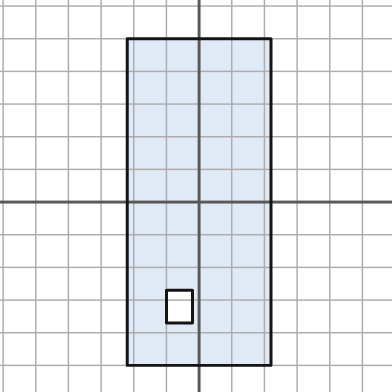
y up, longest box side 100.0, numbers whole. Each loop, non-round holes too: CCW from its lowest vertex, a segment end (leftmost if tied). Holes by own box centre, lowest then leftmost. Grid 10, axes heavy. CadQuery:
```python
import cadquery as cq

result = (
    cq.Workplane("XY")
    .moveTo(-22.0, -50.0)
    .lineTo(22.0, -50.0)
    .lineTo(22.0, 50.0)
    .lineTo(-22.0, 50.0)
    .close()
    .moveTo(-10.0, -37.0)
    .lineTo(-2.0, -37.0)
    .lineTo(-2.0, -27.0)
    .lineTo(-10.0, -27.0)
    .close()
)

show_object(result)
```